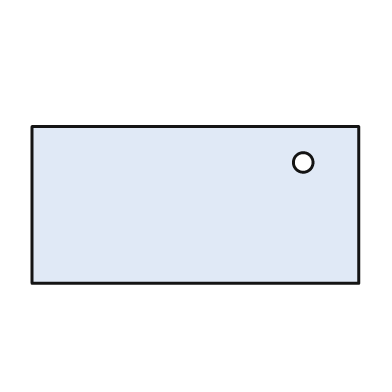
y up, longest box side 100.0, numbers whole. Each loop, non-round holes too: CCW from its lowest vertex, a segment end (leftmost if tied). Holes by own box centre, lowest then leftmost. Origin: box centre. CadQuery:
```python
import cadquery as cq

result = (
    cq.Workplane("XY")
    .moveTo(-50.0, -24.0)
    .lineTo(50.0, -24.0)
    .lineTo(50.0, 24.0)
    .lineTo(-50.0, 24.0)
    .close()
    .moveTo(33.0, 13.0)
    .circle(3.0)
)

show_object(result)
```